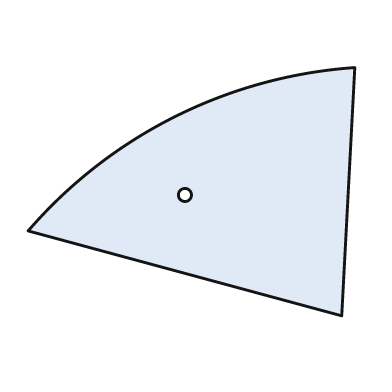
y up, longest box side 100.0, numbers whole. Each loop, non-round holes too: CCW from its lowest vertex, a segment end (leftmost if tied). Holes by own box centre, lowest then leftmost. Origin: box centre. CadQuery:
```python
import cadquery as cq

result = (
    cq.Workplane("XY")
    .moveTo(46.0, -38.0)
    .lineTo(50.0, 38.0)
    .threePointArc((-5.0, 23.0), (-50.0, -12.0))
    .close()
    .moveTo(-2.0, -1.0)
    .circle(2.0)
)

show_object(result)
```